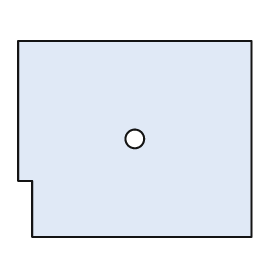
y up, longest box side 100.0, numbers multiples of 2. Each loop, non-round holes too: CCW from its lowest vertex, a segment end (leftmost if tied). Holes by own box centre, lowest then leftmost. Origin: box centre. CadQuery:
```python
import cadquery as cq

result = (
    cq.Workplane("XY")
    .moveTo(-44.0, -42.0)
    .lineTo(50.0, -42.0)
    .lineTo(50.0, 42.0)
    .lineTo(-50.0, 42.0)
    .lineTo(-50.0, -18.0)
    .lineTo(-44.0, -18.0)
    .close()
    .moveTo(0.0, 0.0)
    .circle(4.0)
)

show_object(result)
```